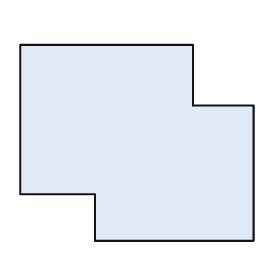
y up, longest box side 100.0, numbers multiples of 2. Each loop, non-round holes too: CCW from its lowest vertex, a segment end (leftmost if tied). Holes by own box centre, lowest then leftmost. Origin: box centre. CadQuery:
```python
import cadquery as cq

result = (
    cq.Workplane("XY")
    .moveTo(-18.0, -42.0)
    .lineTo(50.0, -42.0)
    .lineTo(50.0, 16.0)
    .lineTo(24.0, 16.0)
    .lineTo(24.0, 42.0)
    .lineTo(-50.0, 42.0)
    .lineTo(-50.0, -22.0)
    .lineTo(-18.0, -22.0)
    .close()
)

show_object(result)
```